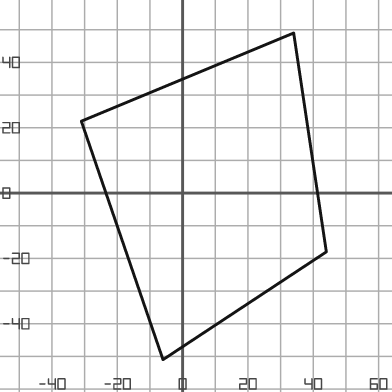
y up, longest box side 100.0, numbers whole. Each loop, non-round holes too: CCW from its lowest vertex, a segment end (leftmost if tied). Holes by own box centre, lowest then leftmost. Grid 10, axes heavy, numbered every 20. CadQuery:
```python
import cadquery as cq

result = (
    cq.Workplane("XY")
    .moveTo(-6.0, -51.0)
    .lineTo(44.0, -18.0)
    .lineTo(34.0, 49.0)
    .lineTo(-31.0, 22.0)
    .close()
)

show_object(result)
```